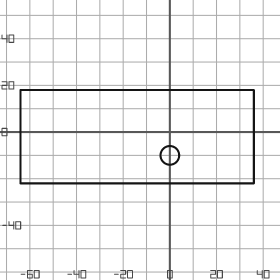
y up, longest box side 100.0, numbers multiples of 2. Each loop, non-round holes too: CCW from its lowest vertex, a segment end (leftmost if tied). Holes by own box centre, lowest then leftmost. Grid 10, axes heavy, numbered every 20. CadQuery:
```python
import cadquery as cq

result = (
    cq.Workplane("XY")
    .moveTo(-64.0, -22.0)
    .lineTo(36.0, -22.0)
    .lineTo(36.0, 18.0)
    .lineTo(-64.0, 18.0)
    .close()
    .moveTo(0.0, -10.0)
    .circle(4.0)
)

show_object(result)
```